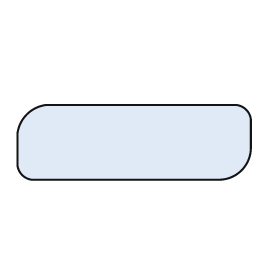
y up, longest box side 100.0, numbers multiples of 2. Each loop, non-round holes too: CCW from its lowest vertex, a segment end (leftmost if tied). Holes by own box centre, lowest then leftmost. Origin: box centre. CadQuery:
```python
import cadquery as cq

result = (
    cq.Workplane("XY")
    .moveTo(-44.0, -16.0)
    .lineTo(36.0, -16.0)
    .threePointArc((46.0, -12.0), (50.0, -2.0))
    .lineTo(50.0, 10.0)
    .threePointArc((48.0, 14.0), (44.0, 16.0))
    .lineTo(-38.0, 16.0)
    .threePointArc((-46.0, 12.0), (-50.0, 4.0))
    .lineTo(-50.0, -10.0)
    .threePointArc((-48.0, -14.0), (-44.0, -16.0))
    .close()
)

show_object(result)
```